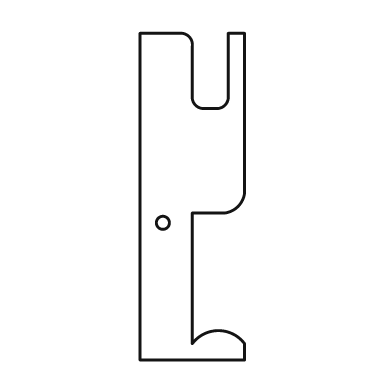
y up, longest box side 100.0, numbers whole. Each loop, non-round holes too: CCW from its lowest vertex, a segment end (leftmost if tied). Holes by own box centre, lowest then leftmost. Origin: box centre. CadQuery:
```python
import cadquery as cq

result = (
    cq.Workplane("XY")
    .moveTo(-16.0, -50.0)
    .lineTo(16.0, -50.0)
    .lineTo(16.0, -45.0)
    .threePointArc((8.0, -41.0), (0.0, -45.0))
    .lineTo(0.0, -5.0)
    .lineTo(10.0, -5.0)
    .threePointArc((14.0, -3.0), (16.0, 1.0))
    .lineTo(16.0, 50.0)
    .lineTo(11.0, 50.0)
    .lineTo(11.0, 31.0)
    .threePointArc((10.0, 28.0), (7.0, 27.0))
    .lineTo(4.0, 27.0)
    .threePointArc((1.0, 28.0), (0.0, 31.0))
    .lineTo(0.0, 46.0)
    .threePointArc((-1.0, 49.0), (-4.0, 50.0))
    .lineTo(-16.0, 50.0)
    .close()
    .moveTo(-9.0, -8.0)
    .circle(2.0)
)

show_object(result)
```